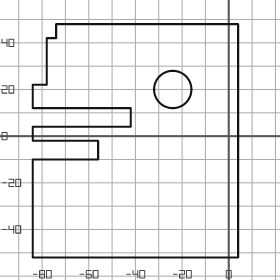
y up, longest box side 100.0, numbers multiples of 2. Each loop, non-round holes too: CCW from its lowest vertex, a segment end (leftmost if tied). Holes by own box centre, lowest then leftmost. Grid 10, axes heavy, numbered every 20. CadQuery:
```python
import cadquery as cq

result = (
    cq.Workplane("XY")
    .moveTo(-84.0, -52.0)
    .lineTo(4.0, -52.0)
    .lineTo(4.0, 48.0)
    .lineTo(-74.0, 48.0)
    .lineTo(-74.0, 42.0)
    .lineTo(-78.0, 42.0)
    .lineTo(-78.0, 22.0)
    .lineTo(-84.0, 22.0)
    .lineTo(-84.0, 12.0)
    .lineTo(-42.0, 12.0)
    .lineTo(-42.0, 4.0)
    .lineTo(-84.0, 4.0)
    .lineTo(-84.0, -2.0)
    .lineTo(-56.0, -2.0)
    .lineTo(-56.0, -10.0)
    .lineTo(-84.0, -10.0)
    .close()
    .moveTo(-24.0, 20.0)
    .circle(8.0)
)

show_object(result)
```